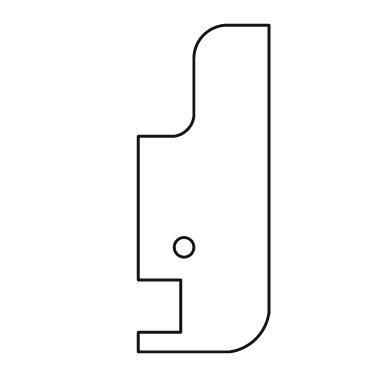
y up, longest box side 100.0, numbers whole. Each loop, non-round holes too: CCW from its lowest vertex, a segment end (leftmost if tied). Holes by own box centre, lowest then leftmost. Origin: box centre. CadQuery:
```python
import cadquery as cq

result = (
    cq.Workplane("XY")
    .moveTo(-20.0, -50.0)
    .lineTo(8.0, -50.0)
    .threePointArc((16.0, -46.0), (20.0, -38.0))
    .lineTo(20.0, 50.0)
    .lineTo(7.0, 50.0)
    .threePointArc((0.0, 47.0), (-3.0, 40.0))
    .lineTo(-3.0, 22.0)
    .threePointArc((-5.0, 18.0), (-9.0, 16.0))
    .lineTo(-20.0, 16.0)
    .lineTo(-20.0, -28.0)
    .lineTo(-7.0, -28.0)
    .lineTo(-7.0, -44.0)
    .lineTo(-20.0, -44.0)
    .close()
    .moveTo(-6.0, -18.0)
    .circle(3.0)
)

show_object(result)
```